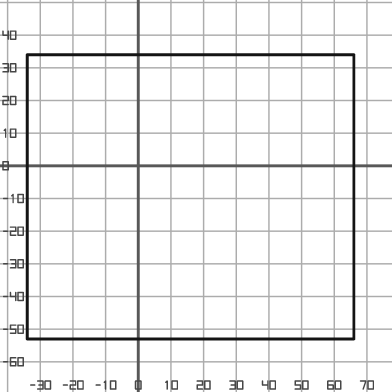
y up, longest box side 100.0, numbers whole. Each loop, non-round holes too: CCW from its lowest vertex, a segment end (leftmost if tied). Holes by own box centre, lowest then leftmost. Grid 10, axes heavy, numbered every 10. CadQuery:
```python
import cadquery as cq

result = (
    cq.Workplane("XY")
    .moveTo(-34.0, -53.0)
    .lineTo(66.0, -53.0)
    .lineTo(66.0, 34.0)
    .lineTo(-34.0, 34.0)
    .close()
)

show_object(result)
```